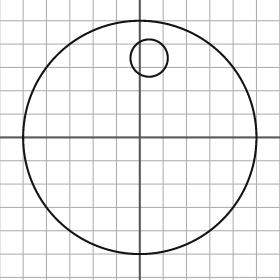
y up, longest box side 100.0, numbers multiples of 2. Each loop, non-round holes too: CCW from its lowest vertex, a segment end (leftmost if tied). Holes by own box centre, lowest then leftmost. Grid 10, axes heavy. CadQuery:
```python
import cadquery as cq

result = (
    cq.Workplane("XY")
    .moveTo(0.0, 0.0)
    .circle(50.0)
    .moveTo(4.0, 34.0)
    .circle(8.0)
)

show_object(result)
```